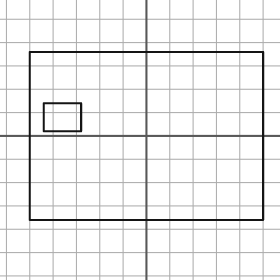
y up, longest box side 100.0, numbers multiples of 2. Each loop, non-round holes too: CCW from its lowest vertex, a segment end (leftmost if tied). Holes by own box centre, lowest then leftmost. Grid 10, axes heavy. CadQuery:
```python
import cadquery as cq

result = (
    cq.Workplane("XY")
    .moveTo(-50.0, -36.0)
    .lineTo(50.0, -36.0)
    .lineTo(50.0, 36.0)
    .lineTo(-50.0, 36.0)
    .close()
    .moveTo(-44.0, 2.0)
    .lineTo(-28.0, 2.0)
    .lineTo(-28.0, 14.0)
    .lineTo(-44.0, 14.0)
    .close()
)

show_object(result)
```